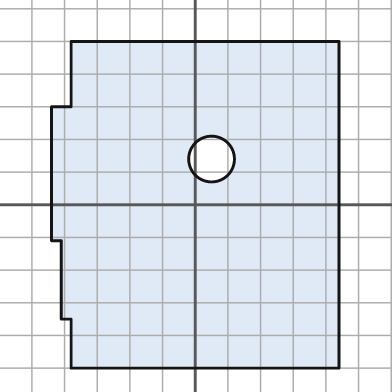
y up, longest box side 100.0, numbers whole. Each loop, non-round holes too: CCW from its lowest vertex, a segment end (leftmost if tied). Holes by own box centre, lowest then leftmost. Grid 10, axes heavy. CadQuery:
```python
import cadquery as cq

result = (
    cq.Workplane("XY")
    .moveTo(-38.0, -50.0)
    .lineTo(44.0, -50.0)
    .lineTo(44.0, 50.0)
    .lineTo(-38.0, 50.0)
    .lineTo(-38.0, 30.0)
    .lineTo(-44.0, 30.0)
    .lineTo(-44.0, -11.0)
    .lineTo(-41.0, -11.0)
    .lineTo(-41.0, -35.0)
    .lineTo(-38.0, -35.0)
    .close()
    .moveTo(5.0, 14.0)
    .circle(7.0)
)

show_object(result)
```